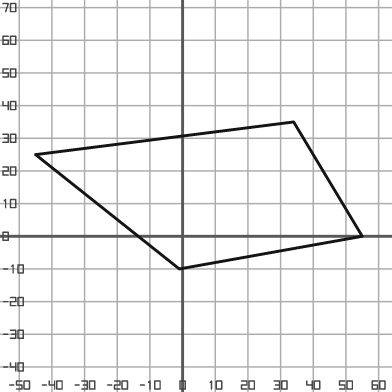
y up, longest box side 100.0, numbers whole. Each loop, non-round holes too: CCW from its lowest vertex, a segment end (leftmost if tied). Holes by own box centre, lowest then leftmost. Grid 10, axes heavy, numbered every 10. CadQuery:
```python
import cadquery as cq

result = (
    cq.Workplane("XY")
    .moveTo(-1.0, -10.0)
    .lineTo(55.0, 0.0)
    .lineTo(34.0, 35.0)
    .lineTo(-45.0, 25.0)
    .close()
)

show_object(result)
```